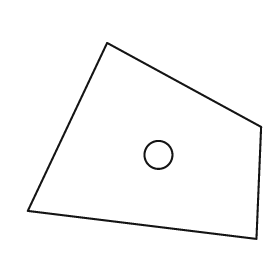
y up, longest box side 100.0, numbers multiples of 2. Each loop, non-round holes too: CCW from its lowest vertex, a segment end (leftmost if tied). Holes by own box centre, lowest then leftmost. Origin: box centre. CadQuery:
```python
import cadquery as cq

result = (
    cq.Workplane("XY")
    .moveTo(48.0, -42.0)
    .lineTo(50.0, 6.0)
    .lineTo(-16.0, 42.0)
    .lineTo(-50.0, -30.0)
    .close()
    .moveTo(6.0, -6.0)
    .circle(6.0)
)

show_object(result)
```